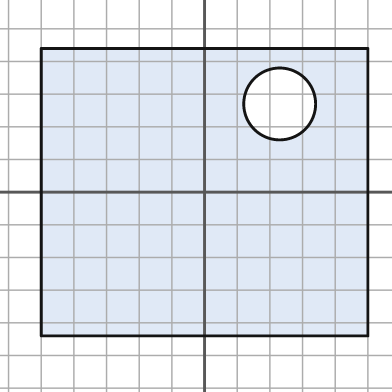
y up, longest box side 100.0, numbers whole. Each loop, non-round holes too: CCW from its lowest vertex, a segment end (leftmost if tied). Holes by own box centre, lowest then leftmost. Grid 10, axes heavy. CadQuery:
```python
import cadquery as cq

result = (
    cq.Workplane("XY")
    .moveTo(-50.0, -44.0)
    .lineTo(50.0, -44.0)
    .lineTo(50.0, 44.0)
    .lineTo(-50.0, 44.0)
    .close()
    .moveTo(23.0, 27.0)
    .circle(11.0)
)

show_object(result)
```